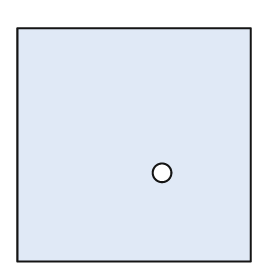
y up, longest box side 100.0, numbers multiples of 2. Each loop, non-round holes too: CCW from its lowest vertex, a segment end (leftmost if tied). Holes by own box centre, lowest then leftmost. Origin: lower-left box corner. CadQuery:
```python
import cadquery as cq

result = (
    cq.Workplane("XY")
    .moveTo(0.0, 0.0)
    .lineTo(100.0, 0.0)
    .lineTo(100.0, 100.0)
    .lineTo(0.0, 100.0)
    .close()
    .moveTo(62.0, 38.0)
    .circle(4.0)
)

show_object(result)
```